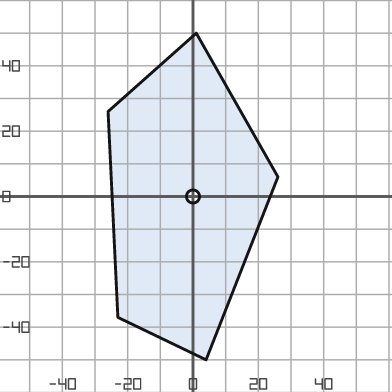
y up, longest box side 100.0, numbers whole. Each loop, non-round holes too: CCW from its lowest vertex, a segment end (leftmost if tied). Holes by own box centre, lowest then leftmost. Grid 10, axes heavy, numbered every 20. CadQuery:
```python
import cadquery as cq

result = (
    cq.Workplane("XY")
    .moveTo(4.0, -50.0)
    .lineTo(26.0, 6.0)
    .lineTo(1.0, 50.0)
    .lineTo(-26.0, 26.0)
    .lineTo(-23.0, -37.0)
    .close()
    .moveTo(0.0, 0.0)
    .circle(2.0)
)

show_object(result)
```